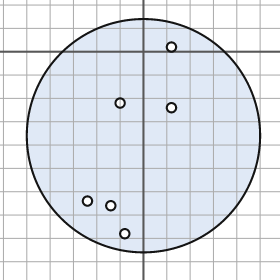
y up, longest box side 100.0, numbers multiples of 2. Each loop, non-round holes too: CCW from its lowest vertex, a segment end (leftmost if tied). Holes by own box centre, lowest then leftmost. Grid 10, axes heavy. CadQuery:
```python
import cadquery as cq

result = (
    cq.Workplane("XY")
    .moveTo(0.0, -36.0)
    .circle(50.0)
    .moveTo(-8.0, -78.0)
    .circle(2.0)
    .moveTo(-14.0, -66.0)
    .circle(2.0)
    .moveTo(-24.0, -64.0)
    .circle(2.0)
    .moveTo(12.0, -24.0)
    .circle(2.0)
    .moveTo(-10.0, -22.0)
    .circle(2.0)
    .moveTo(12.0, 2.0)
    .circle(2.0)
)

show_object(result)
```